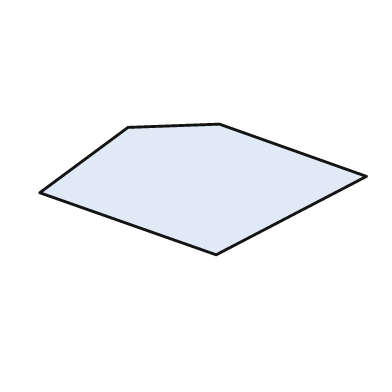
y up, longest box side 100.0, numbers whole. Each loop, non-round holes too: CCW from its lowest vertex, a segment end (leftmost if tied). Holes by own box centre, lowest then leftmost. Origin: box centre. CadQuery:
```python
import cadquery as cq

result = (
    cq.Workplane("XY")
    .moveTo(4.0, -20.0)
    .lineTo(50.0, 4.0)
    .lineTo(5.0, 20.0)
    .lineTo(-23.0, 19.0)
    .lineTo(-50.0, -1.0)
    .close()
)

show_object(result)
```